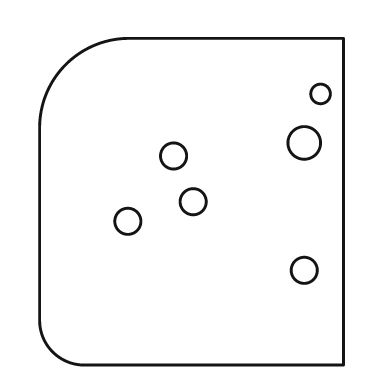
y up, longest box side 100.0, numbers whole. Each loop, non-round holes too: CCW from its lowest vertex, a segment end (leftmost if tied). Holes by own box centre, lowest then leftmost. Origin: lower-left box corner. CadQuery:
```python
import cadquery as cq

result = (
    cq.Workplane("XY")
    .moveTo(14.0, 0.0)
    .lineTo(93.0, 0.0)
    .lineTo(93.0, 100.0)
    .lineTo(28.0, 100.0)
    .threePointArc((8.0, 92.0), (0.0, 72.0))
    .lineTo(0.0, 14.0)
    .threePointArc((4.0, 4.0), (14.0, 0.0))
    .close()
    .moveTo(81.0, 29.0)
    .circle(4.0)
    .moveTo(27.0, 44.0)
    .circle(4.0)
    .moveTo(47.0, 50.0)
    .circle(4.0)
    .moveTo(41.0, 64.0)
    .circle(4.0)
    .moveTo(81.0, 68.0)
    .circle(5.0)
    .moveTo(86.0, 83.0)
    .circle(3.0)
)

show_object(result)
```